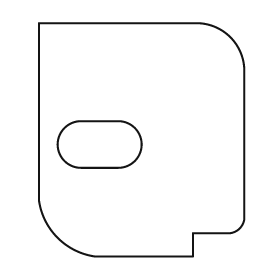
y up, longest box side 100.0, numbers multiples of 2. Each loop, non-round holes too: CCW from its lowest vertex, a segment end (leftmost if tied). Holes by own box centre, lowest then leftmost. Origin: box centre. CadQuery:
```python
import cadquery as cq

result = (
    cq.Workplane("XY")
    .moveTo(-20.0, -50.0)
    .lineTo(22.0, -50.0)
    .lineTo(22.0, -40.0)
    .lineTo(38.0, -40.0)
    .threePointArc((42.0, -38.0), (44.0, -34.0))
    .lineTo(44.0, 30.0)
    .threePointArc((38.0, 44.0), (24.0, 50.0))
    .lineTo(-44.0, 50.0)
    .lineTo(-44.0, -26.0)
    .threePointArc((-36.0, -42.0), (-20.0, -50.0))
    .close()
    .moveTo(-26.0, -12.0)
    .lineTo(-10.0, -12.0)
    .threePointArc((0.0, -2.0), (-10.0, 8.0))
    .lineTo(-26.0, 8.0)
    .threePointArc((-36.0, -2.0), (-26.0, -12.0))
    .close()
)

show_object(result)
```